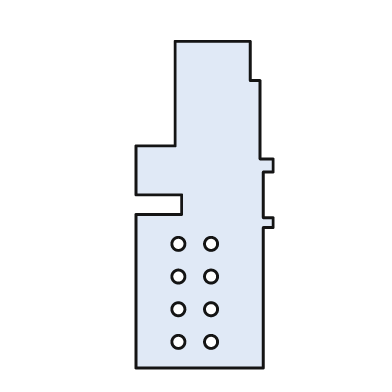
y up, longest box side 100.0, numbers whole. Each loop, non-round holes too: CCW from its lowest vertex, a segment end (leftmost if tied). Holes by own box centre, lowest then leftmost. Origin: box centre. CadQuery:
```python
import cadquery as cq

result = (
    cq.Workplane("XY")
    .moveTo(-21.0, -50.0)
    .lineTo(18.0, -50.0)
    .lineTo(18.0, -7.0)
    .lineTo(21.0, -7.0)
    .lineTo(21.0, -4.0)
    .lineTo(18.0, -4.0)
    .lineTo(18.0, 10.0)
    .lineTo(21.0, 10.0)
    .lineTo(21.0, 14.0)
    .lineTo(17.0, 14.0)
    .lineTo(17.0, 38.0)
    .lineTo(14.0, 38.0)
    .lineTo(14.0, 50.0)
    .lineTo(-9.0, 50.0)
    .lineTo(-9.0, 18.0)
    .lineTo(-21.0, 18.0)
    .lineTo(-21.0, 3.0)
    .lineTo(-7.0, 3.0)
    .lineTo(-7.0, -3.0)
    .lineTo(-21.0, -3.0)
    .close()
    .moveTo(-8.0, -42.0)
    .circle(2.0)
    .moveTo(2.0, -42.0)
    .circle(2.0)
    .moveTo(-8.0, -32.0)
    .circle(2.0)
    .moveTo(2.0, -32.0)
    .circle(2.0)
    .moveTo(-8.0, -22.0)
    .circle(2.0)
    .moveTo(2.0, -22.0)
    .circle(2.0)
    .moveTo(-8.0, -12.0)
    .circle(2.0)
    .moveTo(2.0, -12.0)
    .circle(2.0)
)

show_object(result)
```